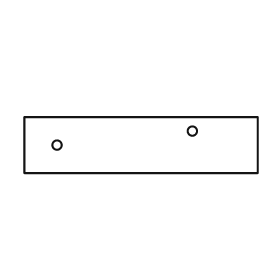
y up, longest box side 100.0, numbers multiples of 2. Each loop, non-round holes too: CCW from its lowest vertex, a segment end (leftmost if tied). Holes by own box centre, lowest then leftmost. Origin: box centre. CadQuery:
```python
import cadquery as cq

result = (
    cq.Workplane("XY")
    .moveTo(-50.0, -12.0)
    .lineTo(50.0, -12.0)
    .lineTo(50.0, 12.0)
    .lineTo(-50.0, 12.0)
    .close()
    .moveTo(-36.0, 0.0)
    .circle(2.0)
    .moveTo(22.0, 6.0)
    .circle(2.0)
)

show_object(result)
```